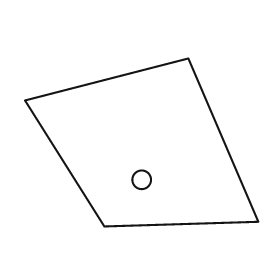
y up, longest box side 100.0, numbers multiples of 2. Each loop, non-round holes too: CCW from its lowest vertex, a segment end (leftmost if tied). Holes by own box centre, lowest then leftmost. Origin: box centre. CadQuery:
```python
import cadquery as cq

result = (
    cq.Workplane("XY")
    .moveTo(-16.0, -36.0)
    .lineTo(50.0, -34.0)
    .lineTo(20.0, 36.0)
    .lineTo(-50.0, 18.0)
    .close()
    .moveTo(0.0, -16.0)
    .circle(4.0)
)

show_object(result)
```